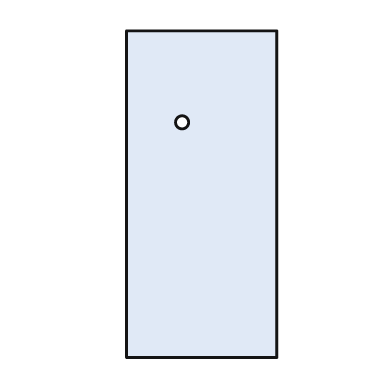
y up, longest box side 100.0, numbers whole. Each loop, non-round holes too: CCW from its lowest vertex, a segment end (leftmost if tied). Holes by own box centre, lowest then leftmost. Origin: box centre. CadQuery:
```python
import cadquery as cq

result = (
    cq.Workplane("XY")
    .moveTo(-23.0, -50.0)
    .lineTo(23.0, -50.0)
    .lineTo(23.0, 50.0)
    .lineTo(-23.0, 50.0)
    .close()
    .moveTo(-6.0, 22.0)
    .circle(2.0)
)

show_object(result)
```